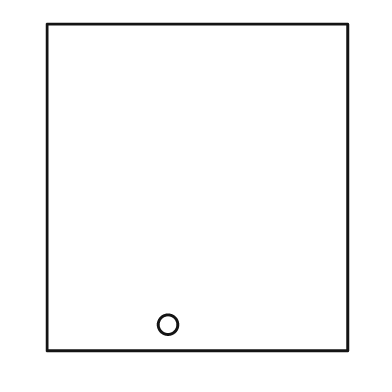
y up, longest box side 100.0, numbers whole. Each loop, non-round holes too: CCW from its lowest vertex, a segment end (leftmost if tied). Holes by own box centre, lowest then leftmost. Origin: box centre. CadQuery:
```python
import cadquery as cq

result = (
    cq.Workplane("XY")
    .moveTo(-46.0, -50.0)
    .lineTo(46.0, -50.0)
    .lineTo(46.0, 50.0)
    .lineTo(-46.0, 50.0)
    .close()
    .moveTo(-9.0, -42.0)
    .circle(3.0)
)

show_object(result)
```